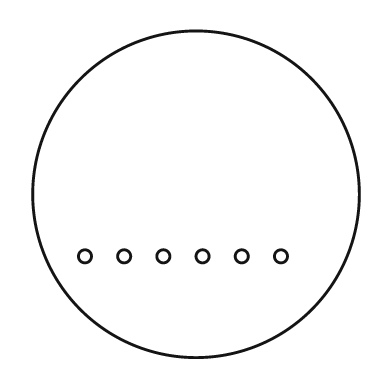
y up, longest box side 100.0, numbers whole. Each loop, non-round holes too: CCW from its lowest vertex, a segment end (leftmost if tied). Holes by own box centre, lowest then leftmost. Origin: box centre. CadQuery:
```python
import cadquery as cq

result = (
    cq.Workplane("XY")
    .moveTo(0.0, 0.0)
    .circle(50.0)
    .moveTo(-34.0, -19.0)
    .circle(2.0)
    .moveTo(-22.0, -19.0)
    .circle(2.0)
    .moveTo(-10.0, -19.0)
    .circle(2.0)
    .moveTo(2.0, -19.0)
    .circle(2.0)
    .moveTo(14.0, -19.0)
    .circle(2.0)
    .moveTo(26.0, -19.0)
    .circle(2.0)
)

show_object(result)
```